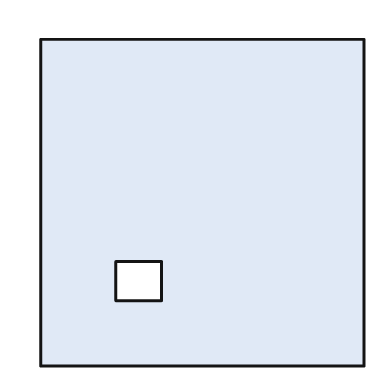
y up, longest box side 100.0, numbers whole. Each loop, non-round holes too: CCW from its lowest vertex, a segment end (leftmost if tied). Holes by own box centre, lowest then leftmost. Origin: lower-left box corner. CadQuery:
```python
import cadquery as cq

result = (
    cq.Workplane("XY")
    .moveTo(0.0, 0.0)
    .lineTo(99.0, 0.0)
    .lineTo(99.0, 100.0)
    .lineTo(0.0, 100.0)
    .close()
    .moveTo(23.0, 20.0)
    .lineTo(37.0, 20.0)
    .lineTo(37.0, 32.0)
    .lineTo(23.0, 32.0)
    .close()
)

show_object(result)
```